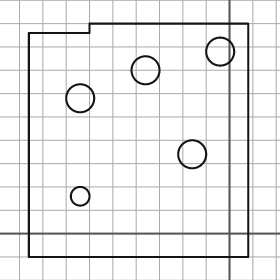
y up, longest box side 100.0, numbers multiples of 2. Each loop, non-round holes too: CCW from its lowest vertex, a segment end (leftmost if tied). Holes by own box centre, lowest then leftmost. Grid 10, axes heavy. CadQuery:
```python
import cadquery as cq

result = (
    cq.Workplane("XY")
    .moveTo(-86.0, -10.0)
    .lineTo(8.0, -10.0)
    .lineTo(8.0, 90.0)
    .lineTo(-60.0, 90.0)
    .lineTo(-60.0, 86.0)
    .lineTo(-86.0, 86.0)
    .close()
    .moveTo(-64.0, 16.0)
    .circle(4.0)
    .moveTo(-16.0, 34.0)
    .circle(6.0)
    .moveTo(-64.0, 58.0)
    .circle(6.0)
    .moveTo(-36.0, 70.0)
    .circle(6.0)
    .moveTo(-4.0, 78.0)
    .circle(6.0)
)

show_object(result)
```